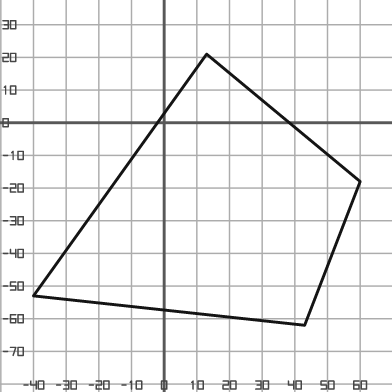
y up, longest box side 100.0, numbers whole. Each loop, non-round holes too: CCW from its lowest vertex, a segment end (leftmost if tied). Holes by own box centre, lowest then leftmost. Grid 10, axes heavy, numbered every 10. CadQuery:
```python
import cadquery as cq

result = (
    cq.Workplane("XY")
    .moveTo(43.0, -62.0)
    .lineTo(60.0, -18.0)
    .lineTo(13.0, 21.0)
    .lineTo(-40.0, -53.0)
    .close()
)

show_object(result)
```